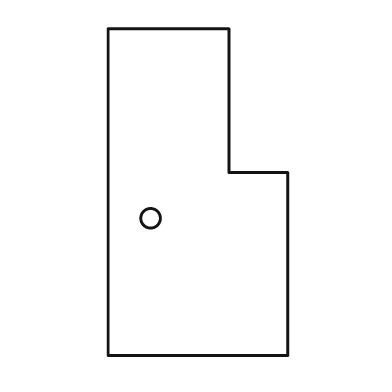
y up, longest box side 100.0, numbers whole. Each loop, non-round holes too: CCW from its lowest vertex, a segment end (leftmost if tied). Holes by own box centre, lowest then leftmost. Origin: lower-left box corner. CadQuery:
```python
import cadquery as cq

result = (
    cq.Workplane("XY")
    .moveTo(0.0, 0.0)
    .lineTo(55.0, 0.0)
    .lineTo(55.0, 56.0)
    .lineTo(37.0, 56.0)
    .lineTo(37.0, 100.0)
    .lineTo(0.0, 100.0)
    .close()
    .moveTo(13.0, 42.0)
    .circle(3.0)
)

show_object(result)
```